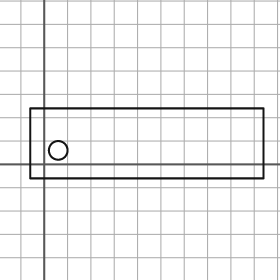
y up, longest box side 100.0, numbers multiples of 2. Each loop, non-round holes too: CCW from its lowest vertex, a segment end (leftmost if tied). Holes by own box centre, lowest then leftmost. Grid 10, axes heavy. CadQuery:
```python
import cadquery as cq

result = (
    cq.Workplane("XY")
    .moveTo(-6.0, -6.0)
    .lineTo(94.0, -6.0)
    .lineTo(94.0, 24.0)
    .lineTo(-6.0, 24.0)
    .close()
    .moveTo(6.0, 6.0)
    .circle(4.0)
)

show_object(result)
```